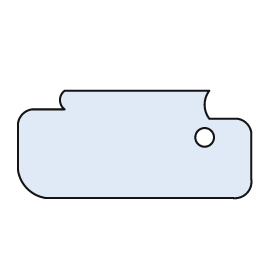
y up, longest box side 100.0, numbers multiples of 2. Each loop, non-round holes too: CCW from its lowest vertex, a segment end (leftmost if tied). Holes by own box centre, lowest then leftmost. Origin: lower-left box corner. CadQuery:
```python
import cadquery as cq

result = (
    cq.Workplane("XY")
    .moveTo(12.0, 0.0)
    .lineTo(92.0, 0.0)
    .threePointArc((98.0, 2.0), (100.0, 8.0))
    .lineTo(100.0, 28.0)
    .threePointArc((98.0, 32.0), (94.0, 34.0))
    .lineTo(82.0, 34.0)
    .threePointArc((80.0, 40.0), (82.0, 46.0))
    .lineTo(20.0, 46.0)
    .threePointArc((18.0, 42.0), (20.0, 38.0))
    .lineTo(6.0, 38.0)
    .threePointArc((2.0, 36.0), (0.0, 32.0))
    .lineTo(0.0, 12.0)
    .threePointArc((4.0, 4.0), (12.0, 0.0))
    .close()
    .moveTo(80.0, 26.0)
    .circle(4.0)
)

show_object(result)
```